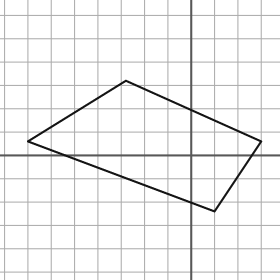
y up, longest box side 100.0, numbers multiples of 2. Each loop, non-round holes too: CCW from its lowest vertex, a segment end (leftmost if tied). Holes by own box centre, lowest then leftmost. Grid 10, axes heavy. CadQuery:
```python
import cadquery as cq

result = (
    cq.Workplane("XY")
    .moveTo(10.0, -24.0)
    .lineTo(30.0, 6.0)
    .lineTo(-28.0, 32.0)
    .lineTo(-70.0, 6.0)
    .close()
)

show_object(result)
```